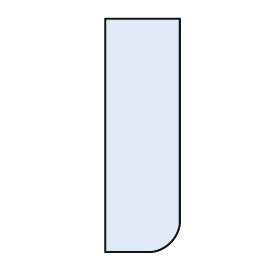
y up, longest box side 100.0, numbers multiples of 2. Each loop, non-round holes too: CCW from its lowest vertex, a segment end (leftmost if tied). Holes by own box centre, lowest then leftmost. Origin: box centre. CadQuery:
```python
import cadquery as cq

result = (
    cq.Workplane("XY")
    .moveTo(-16.0, -50.0)
    .lineTo(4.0, -50.0)
    .threePointArc((12.0, -46.0), (16.0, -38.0))
    .lineTo(16.0, 50.0)
    .lineTo(-16.0, 50.0)
    .close()
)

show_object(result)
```